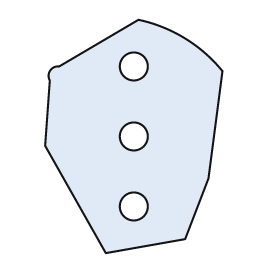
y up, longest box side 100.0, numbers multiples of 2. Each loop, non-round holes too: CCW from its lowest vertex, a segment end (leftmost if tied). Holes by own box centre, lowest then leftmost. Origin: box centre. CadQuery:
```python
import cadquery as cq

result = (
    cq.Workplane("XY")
    .moveTo(-12.0, -50.0)
    .lineTo(22.0, -44.0)
    .lineTo(32.0, -18.0)
    .lineTo(38.0, 28.0)
    .threePointArc((22.0, 42.0), (2.0, 50.0))
    .lineTo(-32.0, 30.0)
    .threePointArc((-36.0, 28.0), (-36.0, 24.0))
    .lineTo(-38.0, -4.0)
    .close()
    .moveTo(0.0, -30.0)
    .circle(6.0)
    .moveTo(0.0, 0.0)
    .circle(6.0)
    .moveTo(0.0, 30.0)
    .circle(6.0)
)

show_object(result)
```